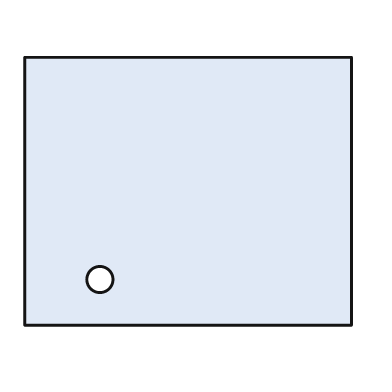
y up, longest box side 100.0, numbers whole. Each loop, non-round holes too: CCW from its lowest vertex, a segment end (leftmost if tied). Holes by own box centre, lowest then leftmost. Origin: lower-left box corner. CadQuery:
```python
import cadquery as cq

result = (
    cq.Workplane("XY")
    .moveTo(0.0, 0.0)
    .lineTo(100.0, 0.0)
    .lineTo(100.0, 82.0)
    .lineTo(0.0, 82.0)
    .close()
    .moveTo(23.0, 14.0)
    .circle(4.0)
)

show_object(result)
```